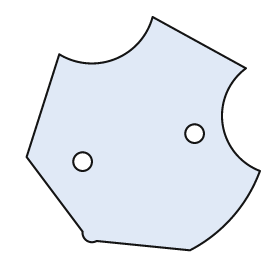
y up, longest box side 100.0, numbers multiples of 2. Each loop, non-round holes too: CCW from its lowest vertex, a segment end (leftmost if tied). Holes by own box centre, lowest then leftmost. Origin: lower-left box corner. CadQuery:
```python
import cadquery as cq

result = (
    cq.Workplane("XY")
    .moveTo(70.0, 0.0)
    .threePointArc((88.0, 14.0), (100.0, 34.0))
    .threePointArc((84.0, 54.0), (94.0, 78.0))
    .lineTo(54.0, 100.0)
    .threePointArc((38.0, 82.0), (14.0, 84.0))
    .lineTo(0.0, 40.0)
    .lineTo(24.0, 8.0)
    .threePointArc((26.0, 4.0), (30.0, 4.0))
    .close()
    .moveTo(24.0, 38.0)
    .circle(4.0)
    .moveTo(72.0, 50.0)
    .circle(4.0)
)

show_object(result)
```